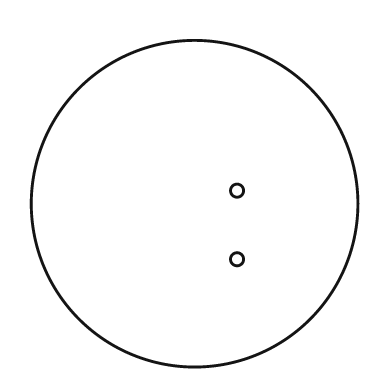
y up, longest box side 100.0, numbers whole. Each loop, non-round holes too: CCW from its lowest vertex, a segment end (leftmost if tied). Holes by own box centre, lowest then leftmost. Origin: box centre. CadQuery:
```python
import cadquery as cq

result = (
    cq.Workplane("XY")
    .moveTo(0.0, 0.0)
    .circle(50.0)
    .moveTo(13.0, -17.0)
    .circle(2.0)
    .moveTo(13.0, 4.0)
    .circle(2.0)
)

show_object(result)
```